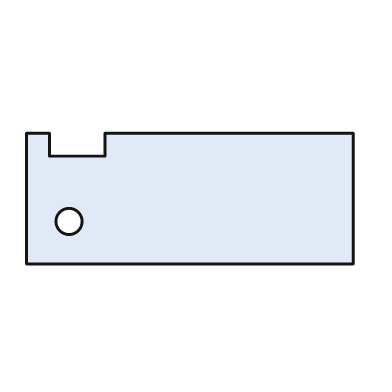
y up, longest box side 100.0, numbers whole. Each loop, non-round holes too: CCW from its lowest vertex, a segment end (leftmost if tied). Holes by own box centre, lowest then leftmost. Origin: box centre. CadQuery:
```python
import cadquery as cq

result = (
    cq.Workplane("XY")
    .moveTo(-50.0, -20.0)
    .lineTo(50.0, -20.0)
    .lineTo(50.0, 20.0)
    .lineTo(-26.0, 20.0)
    .lineTo(-26.0, 13.0)
    .lineTo(-43.0, 13.0)
    .lineTo(-43.0, 20.0)
    .lineTo(-50.0, 20.0)
    .close()
    .moveTo(-37.0, -7.0)
    .circle(4.0)
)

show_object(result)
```